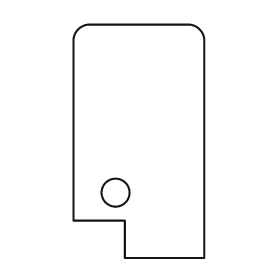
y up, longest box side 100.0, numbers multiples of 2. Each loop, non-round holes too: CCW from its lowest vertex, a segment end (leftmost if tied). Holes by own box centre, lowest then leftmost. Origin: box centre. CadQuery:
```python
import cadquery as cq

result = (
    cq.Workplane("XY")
    .moveTo(-6.0, -50.0)
    .lineTo(28.0, -50.0)
    .lineTo(28.0, 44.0)
    .threePointArc((26.0, 48.0), (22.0, 50.0))
    .lineTo(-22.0, 50.0)
    .threePointArc((-26.0, 48.0), (-28.0, 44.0))
    .lineTo(-28.0, -34.0)
    .lineTo(-6.0, -34.0)
    .close()
    .moveTo(-10.0, -22.0)
    .circle(6.0)
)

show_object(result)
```